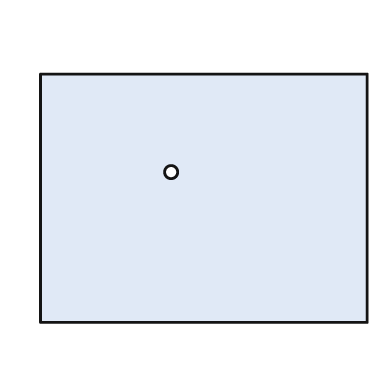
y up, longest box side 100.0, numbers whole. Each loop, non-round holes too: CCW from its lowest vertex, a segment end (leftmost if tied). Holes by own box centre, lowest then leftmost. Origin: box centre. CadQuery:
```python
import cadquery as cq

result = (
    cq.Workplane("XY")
    .moveTo(-50.0, -38.0)
    .lineTo(50.0, -38.0)
    .lineTo(50.0, 38.0)
    .lineTo(-50.0, 38.0)
    .close()
    .moveTo(-10.0, 8.0)
    .circle(2.0)
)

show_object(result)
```